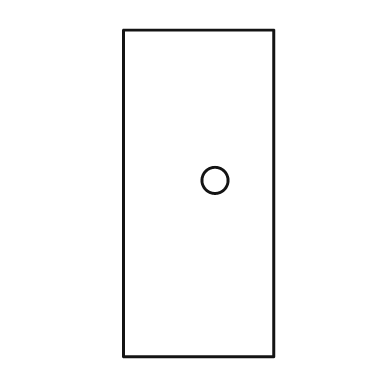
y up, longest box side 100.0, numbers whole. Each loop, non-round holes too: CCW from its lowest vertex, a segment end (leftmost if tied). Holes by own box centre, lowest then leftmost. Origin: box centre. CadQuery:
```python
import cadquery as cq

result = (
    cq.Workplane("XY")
    .moveTo(-23.0, -50.0)
    .lineTo(23.0, -50.0)
    .lineTo(23.0, 50.0)
    .lineTo(-23.0, 50.0)
    .close()
    .moveTo(5.0, 4.0)
    .circle(4.0)
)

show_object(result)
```